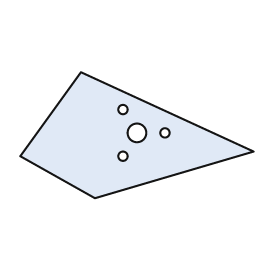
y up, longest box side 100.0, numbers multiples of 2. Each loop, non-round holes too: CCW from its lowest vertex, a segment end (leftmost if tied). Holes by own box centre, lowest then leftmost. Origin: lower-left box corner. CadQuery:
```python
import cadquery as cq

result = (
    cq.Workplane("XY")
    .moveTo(32.0, 0.0)
    .lineTo(100.0, 20.0)
    .lineTo(26.0, 54.0)
    .lineTo(0.0, 18.0)
    .close()
    .moveTo(44.0, 18.0)
    .circle(2.0)
    .moveTo(50.0, 28.0)
    .circle(4.0)
    .moveTo(62.0, 28.0)
    .circle(2.0)
    .moveTo(44.0, 38.0)
    .circle(2.0)
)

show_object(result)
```